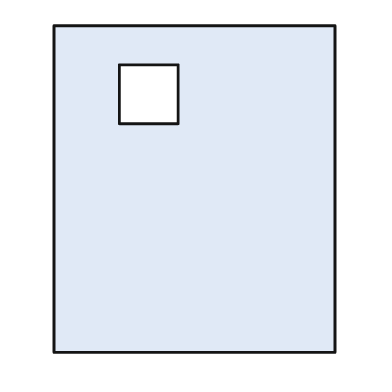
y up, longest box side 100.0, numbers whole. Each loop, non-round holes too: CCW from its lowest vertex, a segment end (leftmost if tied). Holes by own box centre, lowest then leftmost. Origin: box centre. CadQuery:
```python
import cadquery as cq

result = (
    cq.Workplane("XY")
    .moveTo(-43.0, -50.0)
    .lineTo(43.0, -50.0)
    .lineTo(43.0, 50.0)
    .lineTo(-43.0, 50.0)
    .close()
    .moveTo(-23.0, 20.0)
    .lineTo(-5.0, 20.0)
    .lineTo(-5.0, 38.0)
    .lineTo(-23.0, 38.0)
    .close()
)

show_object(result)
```